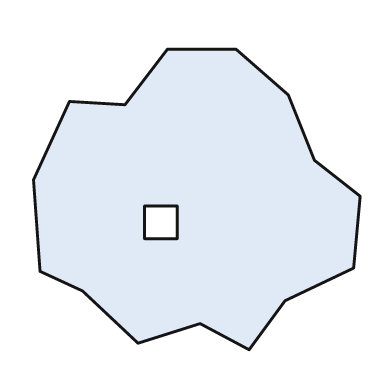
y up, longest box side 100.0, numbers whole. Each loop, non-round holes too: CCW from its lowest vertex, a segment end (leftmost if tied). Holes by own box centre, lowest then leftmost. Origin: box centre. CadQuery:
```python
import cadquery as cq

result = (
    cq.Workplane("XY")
    .moveTo(16.0, -46.0)
    .lineTo(27.0, -31.0)
    .lineTo(48.0, -21.0)
    .lineTo(50.0, 1.0)
    .lineTo(36.0, 12.0)
    .lineTo(28.0, 32.0)
    .lineTo(12.0, 46.0)
    .lineTo(-9.0, 46.0)
    .lineTo(-22.0, 29.0)
    .lineTo(-39.0, 30.0)
    .lineTo(-50.0, 6.0)
    .lineTo(-48.0, -22.0)
    .lineTo(-35.0, -28.0)
    .lineTo(-18.0, -44.0)
    .lineTo(1.0, -38.0)
    .close()
    .moveTo(-16.0, -12.0)
    .lineTo(-6.0, -12.0)
    .lineTo(-6.0, -2.0)
    .lineTo(-16.0, -2.0)
    .close()
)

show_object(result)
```